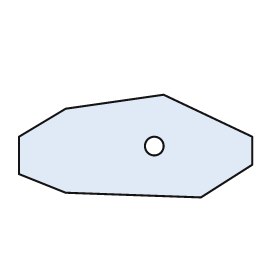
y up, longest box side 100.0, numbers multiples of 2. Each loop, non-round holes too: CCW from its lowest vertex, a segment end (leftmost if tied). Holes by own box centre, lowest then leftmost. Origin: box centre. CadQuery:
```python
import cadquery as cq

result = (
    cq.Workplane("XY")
    .moveTo(28.0, -22.0)
    .lineTo(50.0, -8.0)
    .lineTo(50.0, 4.0)
    .lineTo(12.0, 22.0)
    .lineTo(-30.0, 16.0)
    .lineTo(-50.0, 4.0)
    .lineTo(-50.0, -12.0)
    .lineTo(-30.0, -20.0)
    .close()
    .moveTo(8.0, 0.0)
    .circle(4.0)
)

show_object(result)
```